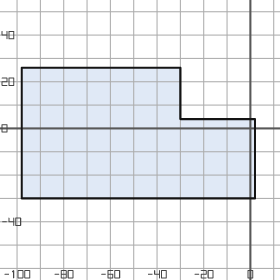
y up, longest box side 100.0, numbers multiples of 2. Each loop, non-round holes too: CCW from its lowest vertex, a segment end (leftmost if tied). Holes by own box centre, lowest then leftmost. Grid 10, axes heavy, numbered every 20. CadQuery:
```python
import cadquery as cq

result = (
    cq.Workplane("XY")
    .moveTo(-98.0, -30.0)
    .lineTo(2.0, -30.0)
    .lineTo(2.0, 4.0)
    .lineTo(-30.0, 4.0)
    .lineTo(-30.0, 26.0)
    .lineTo(-98.0, 26.0)
    .close()
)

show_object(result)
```